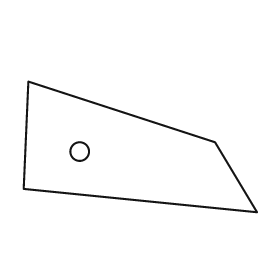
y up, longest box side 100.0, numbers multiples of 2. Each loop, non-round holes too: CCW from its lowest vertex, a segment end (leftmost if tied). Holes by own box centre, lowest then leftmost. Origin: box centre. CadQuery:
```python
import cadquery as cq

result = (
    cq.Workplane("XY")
    .moveTo(50.0, -28.0)
    .lineTo(32.0, 2.0)
    .lineTo(-48.0, 28.0)
    .lineTo(-50.0, -18.0)
    .close()
    .moveTo(-26.0, -2.0)
    .circle(4.0)
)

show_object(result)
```